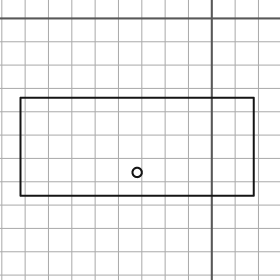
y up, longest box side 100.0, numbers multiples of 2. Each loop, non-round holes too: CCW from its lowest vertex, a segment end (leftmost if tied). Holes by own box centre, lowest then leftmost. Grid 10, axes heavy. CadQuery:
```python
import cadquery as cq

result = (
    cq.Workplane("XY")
    .moveTo(-82.0, -76.0)
    .lineTo(18.0, -76.0)
    .lineTo(18.0, -34.0)
    .lineTo(-82.0, -34.0)
    .close()
    .moveTo(-32.0, -66.0)
    .circle(2.0)
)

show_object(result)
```